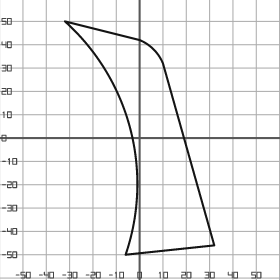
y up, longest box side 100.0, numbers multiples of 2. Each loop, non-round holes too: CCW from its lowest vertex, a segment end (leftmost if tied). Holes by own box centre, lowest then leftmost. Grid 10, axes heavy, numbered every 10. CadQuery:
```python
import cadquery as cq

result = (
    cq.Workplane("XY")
    .moveTo(-6.0, -50.0)
    .lineTo(32.0, -46.0)
    .lineTo(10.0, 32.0)
    .threePointArc((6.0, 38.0), (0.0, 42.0))
    .lineTo(-32.0, 50.0)
    .threePointArc((-4.0, 4.0), (-6.0, -50.0))
    .close()
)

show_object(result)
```